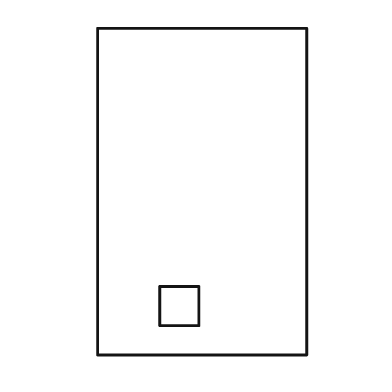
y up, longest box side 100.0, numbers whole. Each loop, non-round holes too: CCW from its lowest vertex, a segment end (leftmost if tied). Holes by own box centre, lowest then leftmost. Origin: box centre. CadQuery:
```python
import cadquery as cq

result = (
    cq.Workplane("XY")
    .moveTo(-32.0, -50.0)
    .lineTo(32.0, -50.0)
    .lineTo(32.0, 50.0)
    .lineTo(-32.0, 50.0)
    .close()
    .moveTo(-13.0, -41.0)
    .lineTo(-1.0, -41.0)
    .lineTo(-1.0, -29.0)
    .lineTo(-13.0, -29.0)
    .close()
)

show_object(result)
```